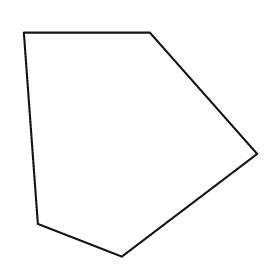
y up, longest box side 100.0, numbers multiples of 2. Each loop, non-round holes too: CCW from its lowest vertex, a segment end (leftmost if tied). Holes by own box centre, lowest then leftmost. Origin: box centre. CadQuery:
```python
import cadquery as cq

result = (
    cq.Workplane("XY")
    .moveTo(-8.0, -48.0)
    .lineTo(50.0, -4.0)
    .lineTo(4.0, 48.0)
    .lineTo(-50.0, 48.0)
    .lineTo(-44.0, -34.0)
    .close()
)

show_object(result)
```